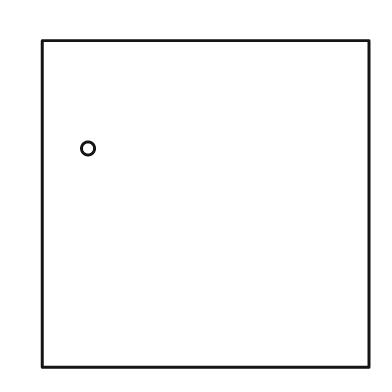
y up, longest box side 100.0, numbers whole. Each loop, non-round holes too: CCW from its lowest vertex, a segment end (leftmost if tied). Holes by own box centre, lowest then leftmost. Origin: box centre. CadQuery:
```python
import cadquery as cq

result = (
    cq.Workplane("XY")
    .moveTo(-50.0, -50.0)
    .lineTo(50.0, -50.0)
    .lineTo(50.0, 50.0)
    .lineTo(-50.0, 50.0)
    .close()
    .moveTo(-36.0, 17.0)
    .circle(2.0)
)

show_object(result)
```